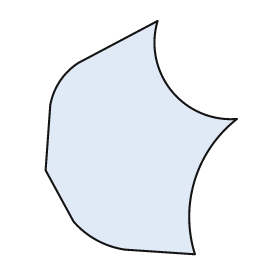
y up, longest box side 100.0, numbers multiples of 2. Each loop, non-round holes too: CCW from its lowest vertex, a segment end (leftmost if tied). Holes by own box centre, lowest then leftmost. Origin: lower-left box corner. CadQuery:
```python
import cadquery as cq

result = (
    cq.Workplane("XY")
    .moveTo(64.0, 0.0)
    .threePointArc((64.0, 32.0), (82.0, 58.0))
    .threePointArc((54.0, 70.0), (48.0, 100.0))
    .lineTo(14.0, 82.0)
    .threePointArc((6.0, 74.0), (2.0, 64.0))
    .lineTo(0.0, 36.0)
    .lineTo(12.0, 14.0)
    .threePointArc((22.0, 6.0), (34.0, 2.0))
    .close()
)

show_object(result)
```